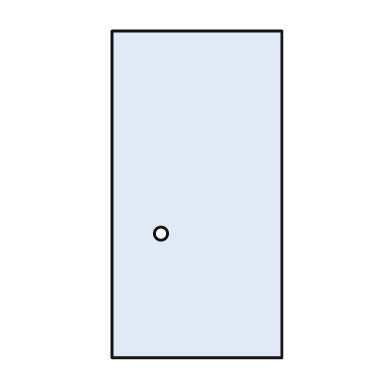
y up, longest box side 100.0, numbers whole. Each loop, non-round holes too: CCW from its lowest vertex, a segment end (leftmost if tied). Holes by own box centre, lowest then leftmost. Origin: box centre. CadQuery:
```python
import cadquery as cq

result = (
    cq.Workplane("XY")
    .moveTo(-26.0, -50.0)
    .lineTo(26.0, -50.0)
    .lineTo(26.0, 50.0)
    .lineTo(-26.0, 50.0)
    .close()
    .moveTo(-11.0, -12.0)
    .circle(2.0)
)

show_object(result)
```